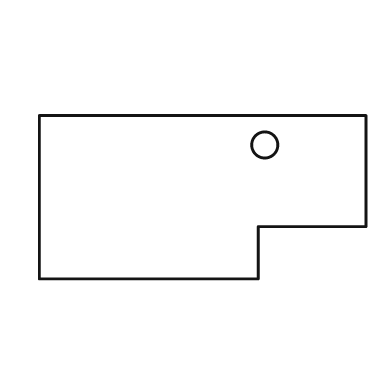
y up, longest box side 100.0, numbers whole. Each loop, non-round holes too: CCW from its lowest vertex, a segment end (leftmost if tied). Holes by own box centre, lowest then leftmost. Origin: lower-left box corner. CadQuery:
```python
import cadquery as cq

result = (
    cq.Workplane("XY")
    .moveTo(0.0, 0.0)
    .lineTo(67.0, 0.0)
    .lineTo(67.0, 16.0)
    .lineTo(100.0, 16.0)
    .lineTo(100.0, 50.0)
    .lineTo(0.0, 50.0)
    .close()
    .moveTo(69.0, 41.0)
    .circle(4.0)
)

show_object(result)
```